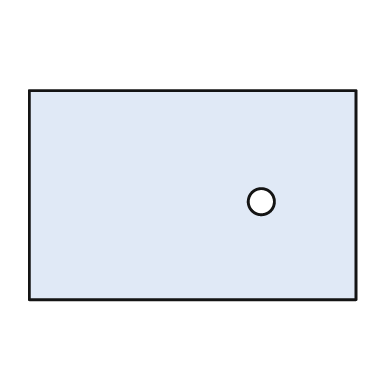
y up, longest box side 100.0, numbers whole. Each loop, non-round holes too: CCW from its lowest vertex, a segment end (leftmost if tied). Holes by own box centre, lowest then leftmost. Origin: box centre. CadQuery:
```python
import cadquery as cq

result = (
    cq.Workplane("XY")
    .moveTo(-50.0, -32.0)
    .lineTo(50.0, -32.0)
    .lineTo(50.0, 32.0)
    .lineTo(-50.0, 32.0)
    .close()
    .moveTo(21.0, -2.0)
    .circle(4.0)
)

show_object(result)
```